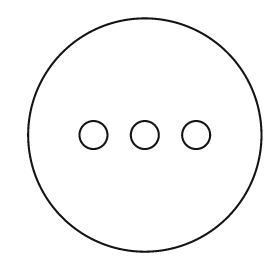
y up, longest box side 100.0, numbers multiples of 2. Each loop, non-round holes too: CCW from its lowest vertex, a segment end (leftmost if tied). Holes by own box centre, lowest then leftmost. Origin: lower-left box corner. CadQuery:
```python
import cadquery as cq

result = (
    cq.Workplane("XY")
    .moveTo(50.0, 50.0)
    .circle(50.0)
    .moveTo(28.0, 50.0)
    .circle(6.0)
    .moveTo(50.0, 50.0)
    .circle(6.0)
    .moveTo(72.0, 50.0)
    .circle(6.0)
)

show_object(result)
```